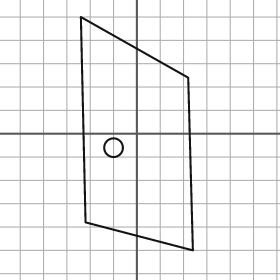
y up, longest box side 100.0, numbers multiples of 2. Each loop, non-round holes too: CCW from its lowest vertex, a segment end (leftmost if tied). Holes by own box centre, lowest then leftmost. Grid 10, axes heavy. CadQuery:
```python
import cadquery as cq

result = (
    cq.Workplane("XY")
    .moveTo(24.0, -50.0)
    .lineTo(22.0, 24.0)
    .lineTo(-24.0, 50.0)
    .lineTo(-22.0, -38.0)
    .close()
    .moveTo(-10.0, -6.0)
    .circle(4.0)
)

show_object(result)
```